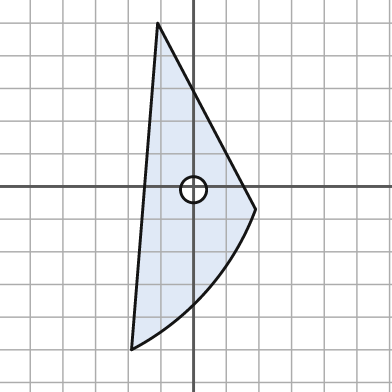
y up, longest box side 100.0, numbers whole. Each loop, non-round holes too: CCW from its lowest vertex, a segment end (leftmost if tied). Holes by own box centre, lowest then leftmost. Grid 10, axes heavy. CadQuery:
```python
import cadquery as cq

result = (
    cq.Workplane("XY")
    .moveTo(-19.0, -50.0)
    .threePointArc((4.0, -32.0), (19.0, -7.0))
    .lineTo(-11.0, 50.0)
    .close()
    .moveTo(0.0, -1.0)
    .circle(4.0)
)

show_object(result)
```